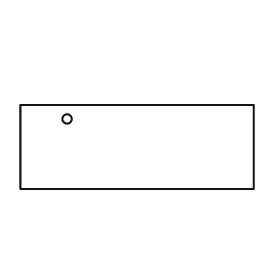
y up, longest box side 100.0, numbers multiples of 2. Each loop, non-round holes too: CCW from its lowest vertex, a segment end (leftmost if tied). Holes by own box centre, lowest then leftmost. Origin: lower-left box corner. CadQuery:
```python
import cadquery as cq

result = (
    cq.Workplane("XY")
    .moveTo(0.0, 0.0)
    .lineTo(100.0, 0.0)
    .lineTo(100.0, 36.0)
    .lineTo(0.0, 36.0)
    .close()
    .moveTo(20.0, 30.0)
    .circle(2.0)
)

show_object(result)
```